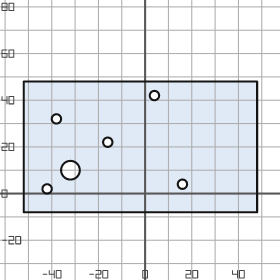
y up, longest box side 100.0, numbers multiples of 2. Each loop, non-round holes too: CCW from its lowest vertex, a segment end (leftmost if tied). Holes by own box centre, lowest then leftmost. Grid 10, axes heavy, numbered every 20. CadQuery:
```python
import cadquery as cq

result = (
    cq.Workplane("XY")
    .moveTo(-52.0, -8.0)
    .lineTo(48.0, -8.0)
    .lineTo(48.0, 48.0)
    .lineTo(-52.0, 48.0)
    .close()
    .moveTo(-42.0, 2.0)
    .circle(2.0)
    .moveTo(16.0, 4.0)
    .circle(2.0)
    .moveTo(-32.0, 10.0)
    .circle(4.0)
    .moveTo(-16.0, 22.0)
    .circle(2.0)
    .moveTo(-38.0, 32.0)
    .circle(2.0)
    .moveTo(4.0, 42.0)
    .circle(2.0)
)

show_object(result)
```